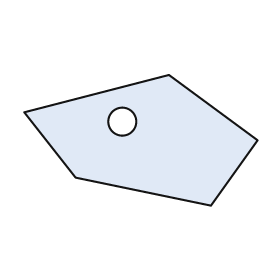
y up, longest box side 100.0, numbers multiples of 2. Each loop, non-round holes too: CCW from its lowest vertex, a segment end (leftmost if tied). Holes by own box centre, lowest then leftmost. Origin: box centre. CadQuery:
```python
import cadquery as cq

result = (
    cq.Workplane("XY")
    .moveTo(30.0, -28.0)
    .lineTo(50.0, 0.0)
    .lineTo(12.0, 28.0)
    .lineTo(-50.0, 12.0)
    .lineTo(-28.0, -16.0)
    .close()
    .moveTo(-8.0, 8.0)
    .circle(6.0)
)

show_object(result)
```